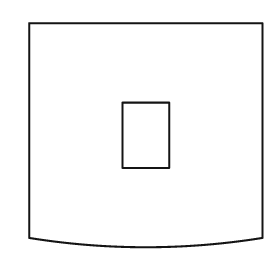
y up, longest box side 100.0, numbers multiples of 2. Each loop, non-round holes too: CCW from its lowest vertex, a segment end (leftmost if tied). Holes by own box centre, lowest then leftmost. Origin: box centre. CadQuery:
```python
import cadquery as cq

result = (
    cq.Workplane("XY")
    .moveTo(-50.0, -44.0)
    .threePointArc((0.0, -48.0), (50.0, -44.0))
    .lineTo(50.0, 48.0)
    .lineTo(-50.0, 48.0)
    .close()
    .moveTo(-10.0, -14.0)
    .lineTo(10.0, -14.0)
    .lineTo(10.0, 14.0)
    .lineTo(-10.0, 14.0)
    .close()
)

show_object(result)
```